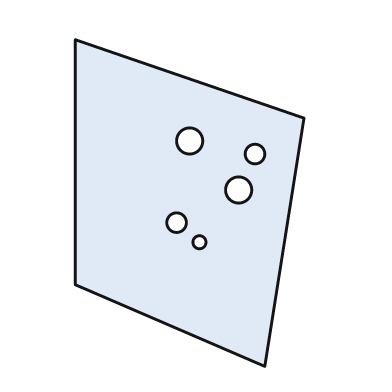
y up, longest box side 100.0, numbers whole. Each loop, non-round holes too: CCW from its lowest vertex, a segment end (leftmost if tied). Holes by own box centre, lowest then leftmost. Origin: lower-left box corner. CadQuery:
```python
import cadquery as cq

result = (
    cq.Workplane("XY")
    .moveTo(58.0, 0.0)
    .lineTo(70.0, 76.0)
    .lineTo(0.0, 100.0)
    .lineTo(0.0, 25.0)
    .close()
    .moveTo(38.0, 38.0)
    .circle(2.0)
    .moveTo(31.0, 44.0)
    .circle(3.0)
    .moveTo(50.0, 54.0)
    .circle(4.0)
    .moveTo(55.0, 65.0)
    .circle(3.0)
    .moveTo(35.0, 69.0)
    .circle(4.0)
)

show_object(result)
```